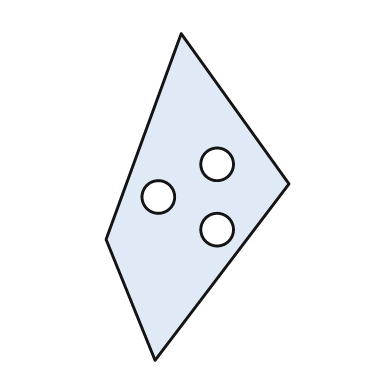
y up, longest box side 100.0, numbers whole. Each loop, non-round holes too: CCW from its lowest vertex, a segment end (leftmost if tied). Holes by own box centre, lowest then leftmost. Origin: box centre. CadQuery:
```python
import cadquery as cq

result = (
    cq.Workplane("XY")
    .moveTo(-13.0, -50.0)
    .lineTo(28.0, 4.0)
    .lineTo(-5.0, 50.0)
    .lineTo(-28.0, -13.0)
    .close()
    .moveTo(6.0, -10.0)
    .circle(5.0)
    .moveTo(-12.0, 0.0)
    .circle(5.0)
    .moveTo(6.0, 10.0)
    .circle(5.0)
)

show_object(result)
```